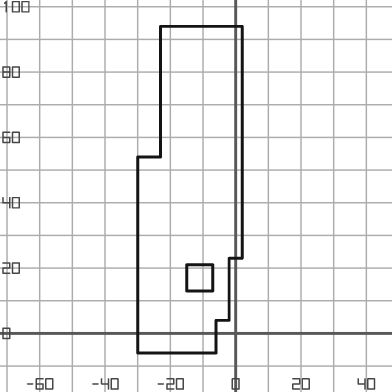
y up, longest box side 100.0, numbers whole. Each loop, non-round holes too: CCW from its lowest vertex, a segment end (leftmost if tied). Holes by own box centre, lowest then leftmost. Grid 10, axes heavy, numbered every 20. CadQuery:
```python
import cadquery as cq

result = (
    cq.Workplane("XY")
    .moveTo(-30.0, -6.0)
    .lineTo(-6.0, -6.0)
    .lineTo(-6.0, 4.0)
    .lineTo(-2.0, 4.0)
    .lineTo(-2.0, 23.0)
    .lineTo(2.0, 23.0)
    .lineTo(2.0, 94.0)
    .lineTo(-23.0, 94.0)
    .lineTo(-23.0, 54.0)
    .lineTo(-30.0, 54.0)
    .close()
    .moveTo(-15.0, 13.0)
    .lineTo(-7.0, 13.0)
    .lineTo(-7.0, 21.0)
    .lineTo(-15.0, 21.0)
    .close()
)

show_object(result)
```